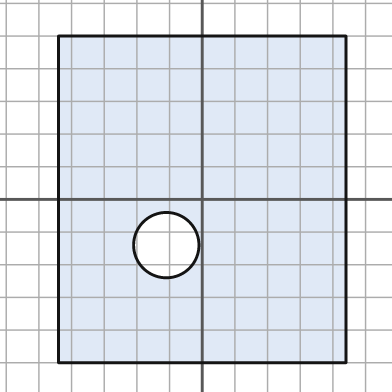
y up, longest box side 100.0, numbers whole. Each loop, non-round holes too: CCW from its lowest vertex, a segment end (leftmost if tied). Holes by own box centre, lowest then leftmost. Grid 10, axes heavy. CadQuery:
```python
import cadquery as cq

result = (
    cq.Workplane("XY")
    .moveTo(-44.0, -50.0)
    .lineTo(44.0, -50.0)
    .lineTo(44.0, 50.0)
    .lineTo(-44.0, 50.0)
    .close()
    .moveTo(-11.0, -14.0)
    .circle(10.0)
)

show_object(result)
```